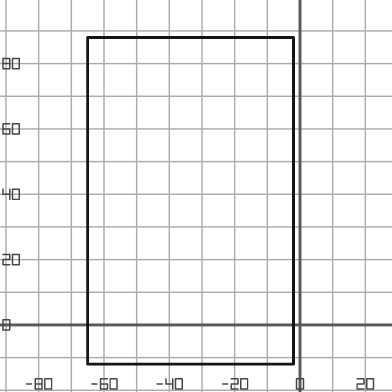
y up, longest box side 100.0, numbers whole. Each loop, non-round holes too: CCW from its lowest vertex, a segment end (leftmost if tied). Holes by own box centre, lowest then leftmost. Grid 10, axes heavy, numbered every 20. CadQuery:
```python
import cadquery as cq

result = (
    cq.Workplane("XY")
    .moveTo(-65.0, -12.0)
    .lineTo(-2.0, -12.0)
    .lineTo(-2.0, 88.0)
    .lineTo(-65.0, 88.0)
    .close()
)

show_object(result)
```